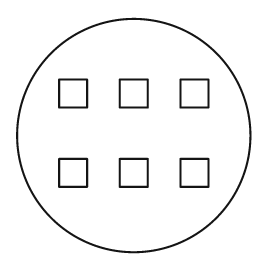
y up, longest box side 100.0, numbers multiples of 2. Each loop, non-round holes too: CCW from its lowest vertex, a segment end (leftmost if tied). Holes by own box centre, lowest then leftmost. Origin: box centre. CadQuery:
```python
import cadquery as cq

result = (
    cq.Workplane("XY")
    .moveTo(0.0, 0.0)
    .circle(50.0)
    .moveTo(-32.0, -22.0)
    .lineTo(-20.0, -22.0)
    .lineTo(-20.0, -10.0)
    .lineTo(-32.0, -10.0)
    .close()
    .moveTo(-6.0, -22.0)
    .lineTo(6.0, -22.0)
    .lineTo(6.0, -10.0)
    .lineTo(-6.0, -10.0)
    .close()
    .moveTo(20.0, -22.0)
    .lineTo(32.0, -22.0)
    .lineTo(32.0, -10.0)
    .lineTo(20.0, -10.0)
    .close()
    .moveTo(-32.0, 12.0)
    .lineTo(-20.0, 12.0)
    .lineTo(-20.0, 24.0)
    .lineTo(-32.0, 24.0)
    .close()
    .moveTo(-6.0, 12.0)
    .lineTo(6.0, 12.0)
    .lineTo(6.0, 24.0)
    .lineTo(-6.0, 24.0)
    .close()
    .moveTo(20.0, 12.0)
    .lineTo(32.0, 12.0)
    .lineTo(32.0, 24.0)
    .lineTo(20.0, 24.0)
    .close()
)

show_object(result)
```